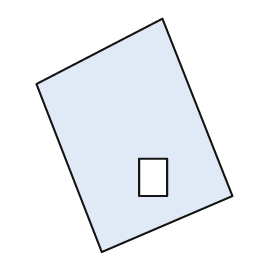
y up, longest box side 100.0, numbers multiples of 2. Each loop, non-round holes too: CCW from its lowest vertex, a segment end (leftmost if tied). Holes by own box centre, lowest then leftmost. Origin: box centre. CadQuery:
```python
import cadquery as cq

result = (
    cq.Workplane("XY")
    .moveTo(-14.0, -50.0)
    .lineTo(42.0, -26.0)
    .lineTo(12.0, 50.0)
    .lineTo(-42.0, 22.0)
    .close()
    .moveTo(2.0, -26.0)
    .lineTo(14.0, -26.0)
    .lineTo(14.0, -10.0)
    .lineTo(2.0, -10.0)
    .close()
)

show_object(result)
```